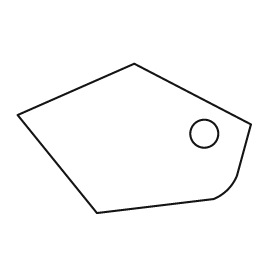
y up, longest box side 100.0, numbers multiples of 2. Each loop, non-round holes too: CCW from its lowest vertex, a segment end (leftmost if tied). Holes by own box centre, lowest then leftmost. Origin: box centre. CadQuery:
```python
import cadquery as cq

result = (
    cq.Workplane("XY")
    .moveTo(-16.0, -32.0)
    .lineTo(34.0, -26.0)
    .threePointArc((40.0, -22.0), (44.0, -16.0))
    .lineTo(50.0, 6.0)
    .lineTo(0.0, 32.0)
    .lineTo(-50.0, 10.0)
    .close()
    .moveTo(30.0, 2.0)
    .circle(6.0)
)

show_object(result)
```